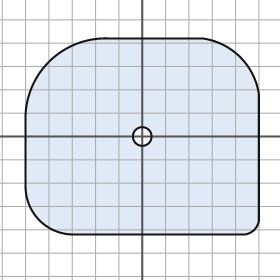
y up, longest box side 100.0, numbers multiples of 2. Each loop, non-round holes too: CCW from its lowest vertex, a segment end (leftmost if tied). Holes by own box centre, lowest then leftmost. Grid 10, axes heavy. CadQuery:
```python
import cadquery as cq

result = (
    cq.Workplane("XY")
    .moveTo(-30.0, -42.0)
    .lineTo(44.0, -42.0)
    .threePointArc((48.0, -40.0), (50.0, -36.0))
    .lineTo(50.0, 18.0)
    .threePointArc((42.0, 34.0), (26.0, 42.0))
    .lineTo(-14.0, 42.0)
    .threePointArc((-40.0, 32.0), (-50.0, 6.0))
    .lineTo(-50.0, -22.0)
    .threePointArc((-44.0, -36.0), (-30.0, -42.0))
    .close()
    .moveTo(0.0, 0.0)
    .circle(4.0)
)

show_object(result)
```